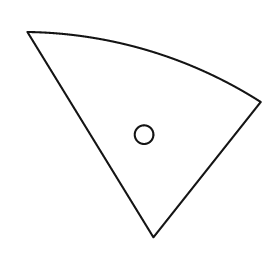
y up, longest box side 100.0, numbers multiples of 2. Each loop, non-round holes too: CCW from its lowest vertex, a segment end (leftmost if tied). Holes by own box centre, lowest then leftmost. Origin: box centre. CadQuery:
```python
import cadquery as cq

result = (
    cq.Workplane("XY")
    .moveTo(4.0, -44.0)
    .lineTo(50.0, 14.0)
    .threePointArc((2.0, 36.0), (-50.0, 44.0))
    .close()
    .moveTo(0.0, 0.0)
    .circle(4.0)
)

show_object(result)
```